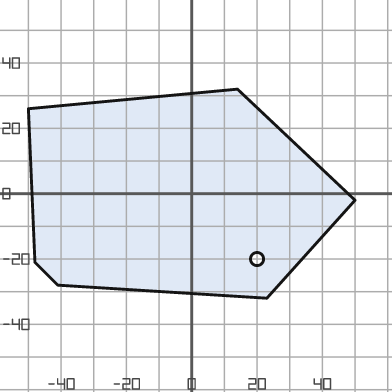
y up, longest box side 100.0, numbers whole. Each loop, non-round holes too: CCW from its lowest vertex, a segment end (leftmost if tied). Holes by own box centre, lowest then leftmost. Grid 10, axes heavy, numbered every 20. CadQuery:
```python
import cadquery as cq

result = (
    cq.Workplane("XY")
    .moveTo(23.0, -32.0)
    .lineTo(50.0, -2.0)
    .lineTo(14.0, 32.0)
    .lineTo(-50.0, 26.0)
    .lineTo(-48.0, -21.0)
    .lineTo(-41.0, -28.0)
    .close()
    .moveTo(20.0, -20.0)
    .circle(2.0)
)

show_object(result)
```